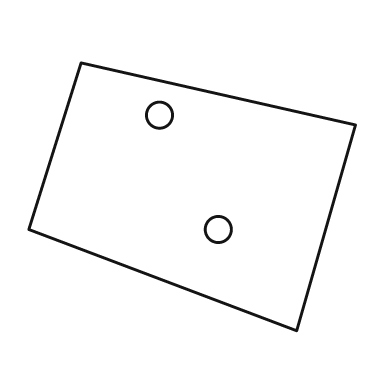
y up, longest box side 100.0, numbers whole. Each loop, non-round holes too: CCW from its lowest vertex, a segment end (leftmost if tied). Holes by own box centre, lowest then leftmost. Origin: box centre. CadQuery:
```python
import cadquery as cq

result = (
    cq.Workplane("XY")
    .moveTo(32.0, -41.0)
    .lineTo(50.0, 22.0)
    .lineTo(-34.0, 41.0)
    .lineTo(-50.0, -10.0)
    .close()
    .moveTo(8.0, -10.0)
    .circle(4.0)
    .moveTo(-10.0, 25.0)
    .circle(4.0)
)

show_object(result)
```